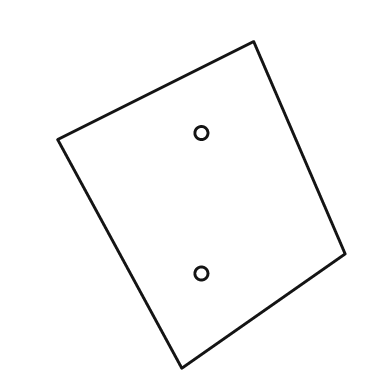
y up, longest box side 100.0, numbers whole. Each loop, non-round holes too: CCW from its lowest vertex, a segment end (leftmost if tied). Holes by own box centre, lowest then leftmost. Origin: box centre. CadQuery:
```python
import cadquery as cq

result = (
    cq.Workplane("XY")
    .moveTo(-6.0, -50.0)
    .lineTo(44.0, -15.0)
    .lineTo(16.0, 50.0)
    .lineTo(-44.0, 20.0)
    .close()
    .moveTo(0.0, -21.0)
    .circle(2.0)
    .moveTo(0.0, 22.0)
    .circle(2.0)
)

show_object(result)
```